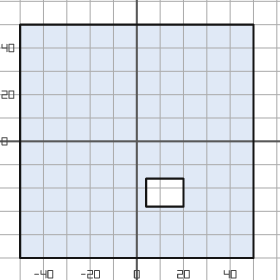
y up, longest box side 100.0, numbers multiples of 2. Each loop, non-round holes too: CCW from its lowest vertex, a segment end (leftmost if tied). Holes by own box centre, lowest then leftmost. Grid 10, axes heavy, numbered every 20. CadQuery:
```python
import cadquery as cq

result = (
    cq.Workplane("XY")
    .moveTo(-50.0, -50.0)
    .lineTo(50.0, -50.0)
    .lineTo(50.0, 50.0)
    .lineTo(-50.0, 50.0)
    .close()
    .moveTo(4.0, -28.0)
    .lineTo(20.0, -28.0)
    .lineTo(20.0, -16.0)
    .lineTo(4.0, -16.0)
    .close()
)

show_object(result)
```